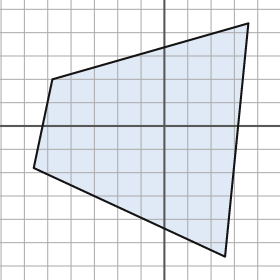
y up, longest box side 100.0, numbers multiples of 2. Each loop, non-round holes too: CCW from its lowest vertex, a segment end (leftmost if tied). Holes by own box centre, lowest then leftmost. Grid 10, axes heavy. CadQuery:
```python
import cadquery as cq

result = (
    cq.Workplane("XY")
    .moveTo(26.0, -56.0)
    .lineTo(36.0, 44.0)
    .lineTo(-48.0, 20.0)
    .lineTo(-56.0, -18.0)
    .close()
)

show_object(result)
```